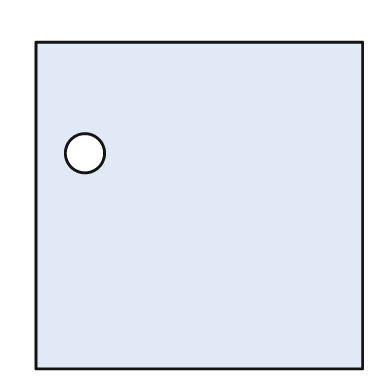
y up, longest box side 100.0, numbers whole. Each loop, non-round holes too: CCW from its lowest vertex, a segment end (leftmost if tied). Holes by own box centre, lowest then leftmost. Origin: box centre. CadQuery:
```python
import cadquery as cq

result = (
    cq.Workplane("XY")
    .moveTo(-50.0, -50.0)
    .lineTo(50.0, -50.0)
    .lineTo(50.0, 50.0)
    .lineTo(-50.0, 50.0)
    .close()
    .moveTo(-35.0, 16.0)
    .circle(6.0)
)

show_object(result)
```